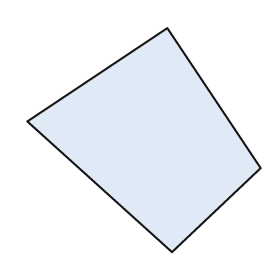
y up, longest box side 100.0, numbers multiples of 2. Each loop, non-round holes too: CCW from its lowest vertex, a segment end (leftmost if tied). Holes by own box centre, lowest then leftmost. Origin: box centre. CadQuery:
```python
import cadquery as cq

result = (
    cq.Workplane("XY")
    .moveTo(12.0, -48.0)
    .lineTo(50.0, -12.0)
    .lineTo(10.0, 48.0)
    .lineTo(-50.0, 8.0)
    .close()
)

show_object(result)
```